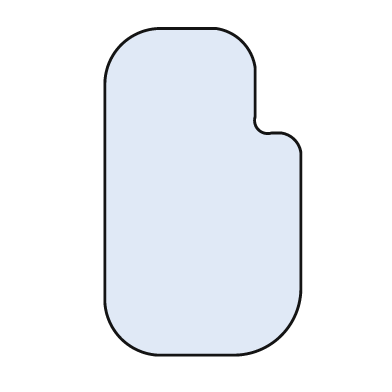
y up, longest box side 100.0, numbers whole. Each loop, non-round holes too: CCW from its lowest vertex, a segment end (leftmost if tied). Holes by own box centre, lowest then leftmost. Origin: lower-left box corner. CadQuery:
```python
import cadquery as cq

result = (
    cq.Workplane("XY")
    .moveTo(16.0, 0.0)
    .lineTo(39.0, 0.0)
    .threePointArc((54.0, 6.0), (60.0, 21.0))
    .lineTo(60.0, 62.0)
    .threePointArc((58.0, 66.0), (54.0, 68.0))
    .lineTo(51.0, 68.0)
    .threePointArc((47.0, 69.0), (46.0, 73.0))
    .lineTo(46.0, 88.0)
    .threePointArc((42.0, 96.0), (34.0, 100.0))
    .lineTo(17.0, 100.0)
    .threePointArc((5.0, 95.0), (0.0, 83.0))
    .lineTo(0.0, 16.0)
    .threePointArc((5.0, 5.0), (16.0, 0.0))
    .close()
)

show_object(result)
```